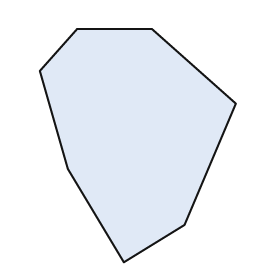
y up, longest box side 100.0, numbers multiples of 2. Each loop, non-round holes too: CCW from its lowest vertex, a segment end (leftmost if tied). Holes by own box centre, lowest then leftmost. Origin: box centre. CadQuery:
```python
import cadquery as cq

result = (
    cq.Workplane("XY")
    .moveTo(-6.0, -50.0)
    .lineTo(20.0, -34.0)
    .lineTo(42.0, 18.0)
    .lineTo(6.0, 50.0)
    .lineTo(-26.0, 50.0)
    .lineTo(-42.0, 32.0)
    .lineTo(-30.0, -10.0)
    .close()
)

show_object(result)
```